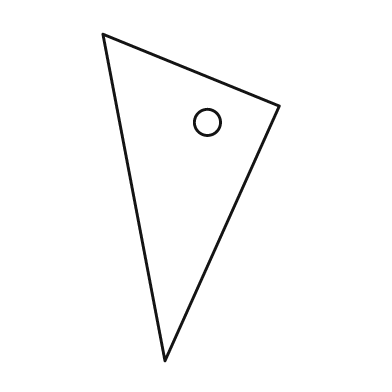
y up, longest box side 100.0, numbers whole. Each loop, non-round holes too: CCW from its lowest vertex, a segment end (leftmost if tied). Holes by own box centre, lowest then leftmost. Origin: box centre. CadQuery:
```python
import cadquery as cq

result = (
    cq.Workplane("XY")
    .moveTo(-8.0, -50.0)
    .lineTo(27.0, 28.0)
    .lineTo(-27.0, 50.0)
    .close()
    .moveTo(5.0, 23.0)
    .circle(4.0)
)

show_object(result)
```